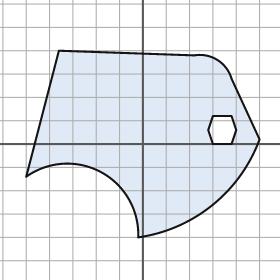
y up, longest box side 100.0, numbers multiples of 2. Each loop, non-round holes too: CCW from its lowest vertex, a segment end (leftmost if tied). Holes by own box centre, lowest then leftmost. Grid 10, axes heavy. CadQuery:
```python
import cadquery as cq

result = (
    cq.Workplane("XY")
    .moveTo(-2.0, -40.0)
    .threePointArc((30.0, -26.0), (50.0, 2.0))
    .lineTo(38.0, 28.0)
    .threePointArc((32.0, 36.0), (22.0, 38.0))
    .lineTo(-36.0, 40.0)
    .lineTo(-50.0, -14.0)
    .threePointArc((-18.0, -12.0), (-2.0, -40.0))
    .close()
    .moveTo(30.0, 0.0)
    .lineTo(38.0, 0.0)
    .lineTo(40.0, 6.0)
    .lineTo(38.0, 12.0)
    .lineTo(30.0, 12.0)
    .lineTo(28.0, 6.0)
    .close()
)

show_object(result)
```